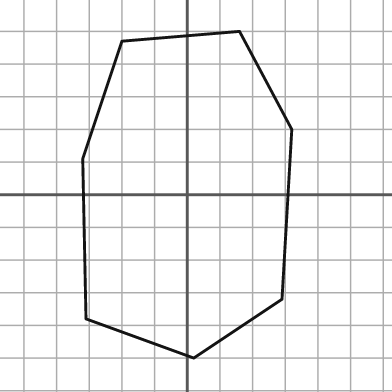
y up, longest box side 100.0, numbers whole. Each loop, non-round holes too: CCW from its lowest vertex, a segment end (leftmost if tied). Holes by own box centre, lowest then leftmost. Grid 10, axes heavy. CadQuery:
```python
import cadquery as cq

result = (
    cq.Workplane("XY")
    .moveTo(2.0, -50.0)
    .lineTo(29.0, -32.0)
    .lineTo(32.0, 20.0)
    .lineTo(16.0, 50.0)
    .lineTo(-20.0, 47.0)
    .lineTo(-32.0, 11.0)
    .lineTo(-31.0, -38.0)
    .close()
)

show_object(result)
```